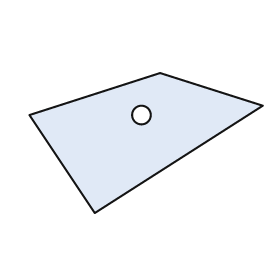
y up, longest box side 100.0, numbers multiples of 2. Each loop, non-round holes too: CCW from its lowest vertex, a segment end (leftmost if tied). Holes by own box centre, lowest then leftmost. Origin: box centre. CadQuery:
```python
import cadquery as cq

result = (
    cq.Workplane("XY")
    .moveTo(-22.0, -30.0)
    .lineTo(50.0, 16.0)
    .lineTo(6.0, 30.0)
    .lineTo(-50.0, 12.0)
    .close()
    .moveTo(-2.0, 12.0)
    .circle(4.0)
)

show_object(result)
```